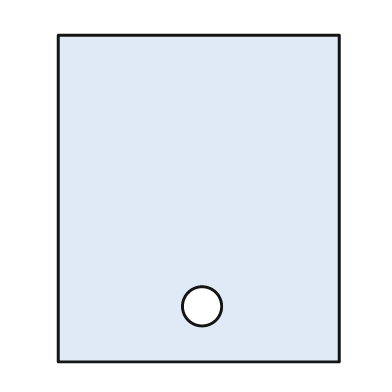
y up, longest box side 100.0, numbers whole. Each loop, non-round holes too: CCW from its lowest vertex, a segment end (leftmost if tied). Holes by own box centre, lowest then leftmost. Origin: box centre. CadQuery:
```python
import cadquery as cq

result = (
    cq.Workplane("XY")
    .moveTo(-43.0, -50.0)
    .lineTo(43.0, -50.0)
    .lineTo(43.0, 50.0)
    .lineTo(-43.0, 50.0)
    .close()
    .moveTo(1.0, -33.0)
    .circle(6.0)
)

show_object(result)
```